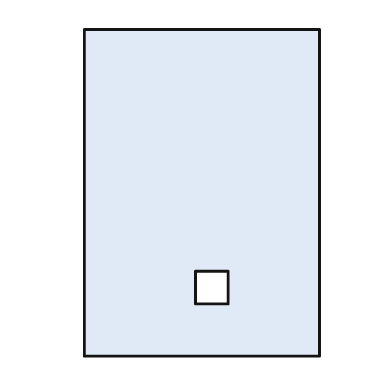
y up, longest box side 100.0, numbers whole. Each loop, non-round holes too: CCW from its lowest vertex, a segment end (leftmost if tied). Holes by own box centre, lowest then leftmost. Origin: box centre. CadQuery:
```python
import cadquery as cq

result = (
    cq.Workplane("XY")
    .moveTo(-36.0, -50.0)
    .lineTo(36.0, -50.0)
    .lineTo(36.0, 50.0)
    .lineTo(-36.0, 50.0)
    .close()
    .moveTo(-2.0, -34.0)
    .lineTo(8.0, -34.0)
    .lineTo(8.0, -24.0)
    .lineTo(-2.0, -24.0)
    .close()
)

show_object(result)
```